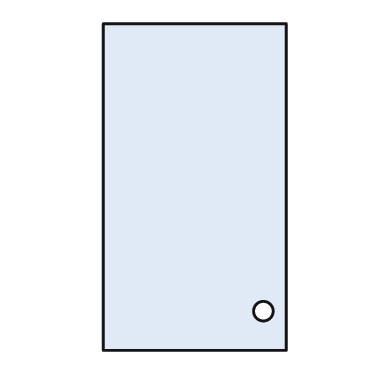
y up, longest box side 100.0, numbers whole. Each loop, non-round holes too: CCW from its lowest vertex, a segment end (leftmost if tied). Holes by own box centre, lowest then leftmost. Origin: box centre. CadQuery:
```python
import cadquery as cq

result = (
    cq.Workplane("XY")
    .moveTo(-28.0, -50.0)
    .lineTo(28.0, -50.0)
    .lineTo(28.0, 50.0)
    .lineTo(-28.0, 50.0)
    .close()
    .moveTo(21.0, -38.0)
    .circle(3.0)
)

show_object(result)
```